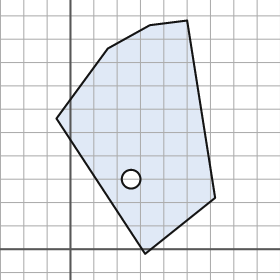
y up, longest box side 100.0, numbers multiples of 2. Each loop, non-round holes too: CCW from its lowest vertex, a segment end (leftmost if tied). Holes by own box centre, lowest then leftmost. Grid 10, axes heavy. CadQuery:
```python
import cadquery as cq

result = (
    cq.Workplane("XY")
    .moveTo(32.0, -2.0)
    .lineTo(62.0, 22.0)
    .lineTo(50.0, 98.0)
    .lineTo(34.0, 96.0)
    .lineTo(16.0, 86.0)
    .lineTo(-6.0, 56.0)
    .close()
    .moveTo(26.0, 30.0)
    .circle(4.0)
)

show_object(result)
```